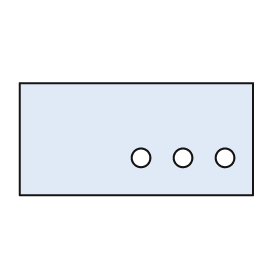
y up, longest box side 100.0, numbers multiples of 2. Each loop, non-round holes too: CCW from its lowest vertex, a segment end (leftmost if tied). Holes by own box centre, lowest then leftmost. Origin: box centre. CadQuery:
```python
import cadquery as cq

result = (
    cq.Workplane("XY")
    .moveTo(-50.0, -24.0)
    .lineTo(50.0, -24.0)
    .lineTo(50.0, 24.0)
    .lineTo(-50.0, 24.0)
    .close()
    .moveTo(2.0, -8.0)
    .circle(4.0)
    .moveTo(20.0, -8.0)
    .circle(4.0)
    .moveTo(38.0, -8.0)
    .circle(4.0)
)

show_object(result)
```